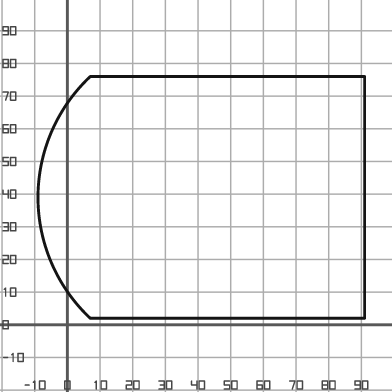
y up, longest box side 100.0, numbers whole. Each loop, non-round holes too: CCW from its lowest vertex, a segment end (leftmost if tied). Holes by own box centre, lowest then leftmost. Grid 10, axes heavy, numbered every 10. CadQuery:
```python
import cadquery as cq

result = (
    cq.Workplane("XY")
    .moveTo(7.0, 2.0)
    .lineTo(91.0, 2.0)
    .lineTo(91.0, 76.0)
    .lineTo(7.0, 76.0)
    .threePointArc((-9.0, 39.0), (7.0, 2.0))
    .close()
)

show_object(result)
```